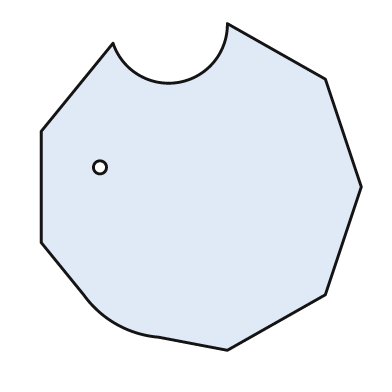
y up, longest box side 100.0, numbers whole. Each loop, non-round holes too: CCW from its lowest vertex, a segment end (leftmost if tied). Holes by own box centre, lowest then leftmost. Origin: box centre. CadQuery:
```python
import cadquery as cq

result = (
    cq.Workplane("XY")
    .moveTo(8.0, -50.0)
    .lineTo(38.0, -33.0)
    .lineTo(49.0, 0.0)
    .lineTo(38.0, 33.0)
    .lineTo(8.0, 50.0)
    .threePointArc((-7.0, 32.0), (-27.0, 44.0))
    .lineTo(-49.0, 17.0)
    .lineTo(-49.0, -17.0)
    .lineTo(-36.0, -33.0)
    .threePointArc((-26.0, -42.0), (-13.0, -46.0))
    .close()
    .moveTo(-31.0, 6.0)
    .circle(2.0)
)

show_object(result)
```